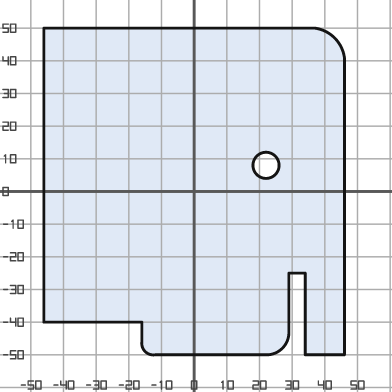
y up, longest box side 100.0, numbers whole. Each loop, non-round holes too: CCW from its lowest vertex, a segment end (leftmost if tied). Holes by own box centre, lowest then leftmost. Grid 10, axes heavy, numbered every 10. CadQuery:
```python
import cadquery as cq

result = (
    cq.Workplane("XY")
    .moveTo(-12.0, -50.0)
    .lineTo(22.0, -50.0)
    .threePointArc((27.0, -48.0), (29.0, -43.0))
    .lineTo(29.0, -25.0)
    .lineTo(34.0, -25.0)
    .lineTo(34.0, -50.0)
    .lineTo(46.0, -50.0)
    .lineTo(46.0, 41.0)
    .threePointArc((43.0, 47.0), (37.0, 50.0))
    .lineTo(-46.0, 50.0)
    .lineTo(-46.0, -40.0)
    .lineTo(-16.0, -40.0)
    .lineTo(-16.0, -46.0)
    .threePointArc((-15.0, -49.0), (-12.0, -50.0))
    .close()
    .moveTo(22.0, 8.0)
    .circle(4.0)
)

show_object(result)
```